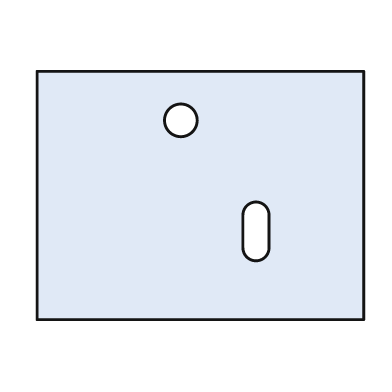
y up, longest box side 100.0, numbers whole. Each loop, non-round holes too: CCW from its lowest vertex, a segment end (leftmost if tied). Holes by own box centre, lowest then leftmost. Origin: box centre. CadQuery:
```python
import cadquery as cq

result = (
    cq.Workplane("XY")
    .moveTo(-50.0, -38.0)
    .lineTo(50.0, -38.0)
    .lineTo(50.0, 38.0)
    .lineTo(-50.0, 38.0)
    .close()
    .moveTo(13.0, -16.0)
    .threePointArc((17.0, -20.0), (21.0, -16.0))
    .lineTo(21.0, -6.0)
    .threePointArc((17.0, -2.0), (13.0, -6.0))
    .close()
    .moveTo(-6.0, 23.0)
    .circle(5.0)
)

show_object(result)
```